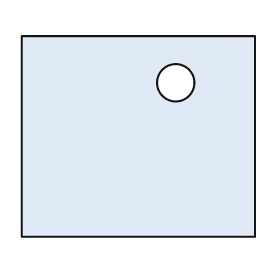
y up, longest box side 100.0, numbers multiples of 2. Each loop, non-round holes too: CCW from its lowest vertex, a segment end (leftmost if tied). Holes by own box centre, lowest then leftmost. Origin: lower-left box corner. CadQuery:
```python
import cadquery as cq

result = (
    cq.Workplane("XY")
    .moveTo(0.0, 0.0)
    .lineTo(100.0, 0.0)
    .lineTo(100.0, 86.0)
    .lineTo(0.0, 86.0)
    .close()
    .moveTo(66.0, 66.0)
    .circle(8.0)
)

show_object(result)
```